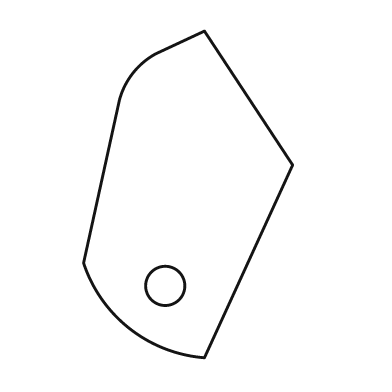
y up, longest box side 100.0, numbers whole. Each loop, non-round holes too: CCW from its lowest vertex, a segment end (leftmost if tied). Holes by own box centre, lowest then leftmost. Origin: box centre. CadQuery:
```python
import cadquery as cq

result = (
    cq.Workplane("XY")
    .moveTo(5.0, -50.0)
    .lineTo(32.0, 9.0)
    .lineTo(5.0, 50.0)
    .lineTo(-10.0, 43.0)
    .threePointArc((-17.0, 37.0), (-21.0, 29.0))
    .lineTo(-32.0, -21.0)
    .threePointArc((-18.0, -41.0), (5.0, -50.0))
    .close()
    .moveTo(-7.0, -28.0)
    .circle(6.0)
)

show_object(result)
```